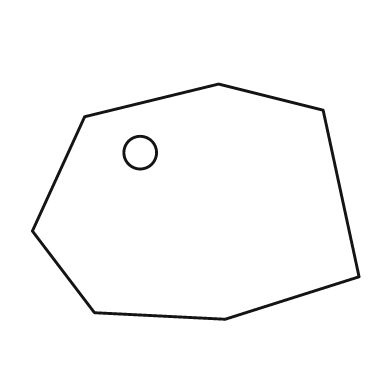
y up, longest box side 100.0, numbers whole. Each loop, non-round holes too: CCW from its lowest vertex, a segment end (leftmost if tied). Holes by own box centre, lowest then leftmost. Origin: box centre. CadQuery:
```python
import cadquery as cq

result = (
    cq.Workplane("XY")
    .moveTo(9.0, -36.0)
    .lineTo(50.0, -23.0)
    .lineTo(39.0, 28.0)
    .lineTo(7.0, 36.0)
    .lineTo(-34.0, 26.0)
    .lineTo(-50.0, -9.0)
    .lineTo(-31.0, -34.0)
    .close()
    .moveTo(-17.0, 15.0)
    .circle(5.0)
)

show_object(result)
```